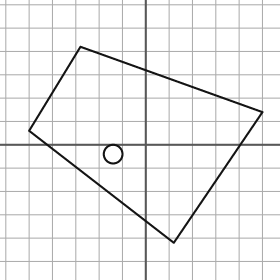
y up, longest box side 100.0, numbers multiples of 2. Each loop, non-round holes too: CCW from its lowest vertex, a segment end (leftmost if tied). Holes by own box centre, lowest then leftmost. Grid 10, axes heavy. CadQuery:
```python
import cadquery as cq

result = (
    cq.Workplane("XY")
    .moveTo(12.0, -42.0)
    .lineTo(50.0, 14.0)
    .lineTo(-28.0, 42.0)
    .lineTo(-50.0, 6.0)
    .close()
    .moveTo(-14.0, -4.0)
    .circle(4.0)
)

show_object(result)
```